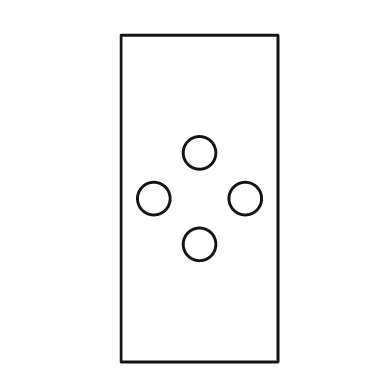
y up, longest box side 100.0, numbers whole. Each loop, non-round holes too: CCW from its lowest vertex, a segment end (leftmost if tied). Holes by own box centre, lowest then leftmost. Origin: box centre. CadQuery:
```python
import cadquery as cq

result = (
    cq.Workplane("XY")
    .moveTo(-24.0, -50.0)
    .lineTo(24.0, -50.0)
    .lineTo(24.0, 50.0)
    .lineTo(-24.0, 50.0)
    .close()
    .moveTo(0.0, -14.0)
    .circle(5.0)
    .moveTo(-14.0, 0.0)
    .circle(5.0)
    .moveTo(14.0, 0.0)
    .circle(5.0)
    .moveTo(0.0, 14.0)
    .circle(5.0)
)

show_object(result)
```